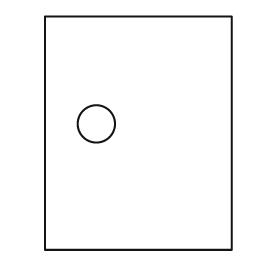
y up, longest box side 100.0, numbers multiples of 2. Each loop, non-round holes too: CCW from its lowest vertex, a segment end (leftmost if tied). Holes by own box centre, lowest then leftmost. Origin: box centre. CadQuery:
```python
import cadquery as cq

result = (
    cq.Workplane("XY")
    .moveTo(-40.0, -50.0)
    .lineTo(40.0, -50.0)
    .lineTo(40.0, 50.0)
    .lineTo(-40.0, 50.0)
    .close()
    .moveTo(-18.0, 4.0)
    .circle(8.0)
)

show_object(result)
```